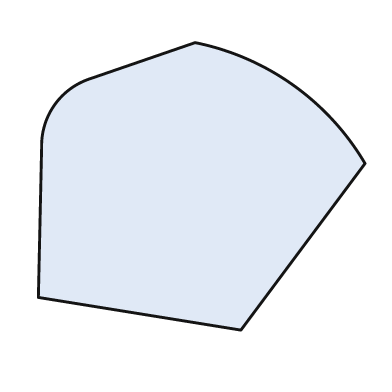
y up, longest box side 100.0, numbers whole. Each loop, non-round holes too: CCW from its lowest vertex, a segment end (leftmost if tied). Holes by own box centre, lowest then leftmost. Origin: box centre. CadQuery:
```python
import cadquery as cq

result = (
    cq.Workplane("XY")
    .moveTo(12.0, -44.0)
    .lineTo(50.0, 7.0)
    .threePointArc((28.0, 31.0), (-2.0, 44.0))
    .lineTo(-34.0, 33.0)
    .threePointArc((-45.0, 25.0), (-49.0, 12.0))
    .lineTo(-50.0, -34.0)
    .close()
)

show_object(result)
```